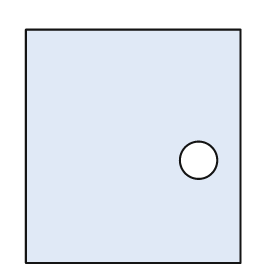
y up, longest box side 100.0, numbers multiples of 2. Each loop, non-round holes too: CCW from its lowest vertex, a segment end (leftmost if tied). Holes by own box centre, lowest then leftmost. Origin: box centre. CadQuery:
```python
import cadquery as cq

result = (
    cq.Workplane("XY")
    .moveTo(-46.0, -50.0)
    .lineTo(46.0, -50.0)
    .lineTo(46.0, 50.0)
    .lineTo(-46.0, 50.0)
    .close()
    .moveTo(28.0, -6.0)
    .circle(8.0)
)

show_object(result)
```